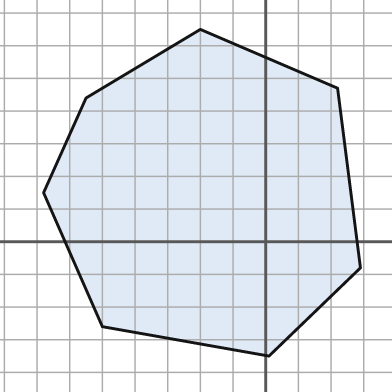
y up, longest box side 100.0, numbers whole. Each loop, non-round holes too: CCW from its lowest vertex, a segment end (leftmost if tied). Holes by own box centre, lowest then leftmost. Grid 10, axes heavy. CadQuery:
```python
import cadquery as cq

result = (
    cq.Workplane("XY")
    .moveTo(1.0, -35.0)
    .lineTo(29.0, -8.0)
    .lineTo(22.0, 47.0)
    .lineTo(-20.0, 65.0)
    .lineTo(-55.0, 44.0)
    .lineTo(-68.0, 15.0)
    .lineTo(-50.0, -26.0)
    .close()
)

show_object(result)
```